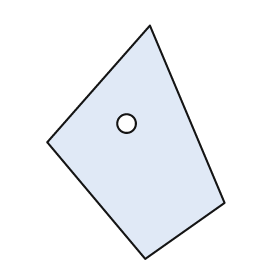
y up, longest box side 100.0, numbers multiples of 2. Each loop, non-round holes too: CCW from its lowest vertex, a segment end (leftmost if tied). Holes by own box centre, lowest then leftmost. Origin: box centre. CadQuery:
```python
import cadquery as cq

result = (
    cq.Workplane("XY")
    .moveTo(4.0, -50.0)
    .lineTo(38.0, -26.0)
    .lineTo(6.0, 50.0)
    .lineTo(-38.0, 0.0)
    .close()
    .moveTo(-4.0, 8.0)
    .circle(4.0)
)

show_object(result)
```